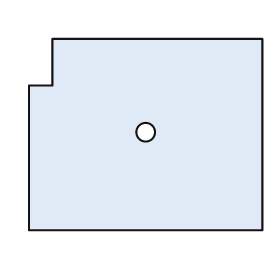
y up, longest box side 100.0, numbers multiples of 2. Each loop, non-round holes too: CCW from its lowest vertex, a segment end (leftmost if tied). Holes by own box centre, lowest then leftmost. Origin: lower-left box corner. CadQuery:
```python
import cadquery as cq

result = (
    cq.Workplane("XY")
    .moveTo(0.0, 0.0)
    .lineTo(100.0, 0.0)
    .lineTo(100.0, 82.0)
    .lineTo(10.0, 82.0)
    .lineTo(10.0, 62.0)
    .lineTo(0.0, 62.0)
    .close()
    .moveTo(50.0, 42.0)
    .circle(4.0)
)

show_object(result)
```